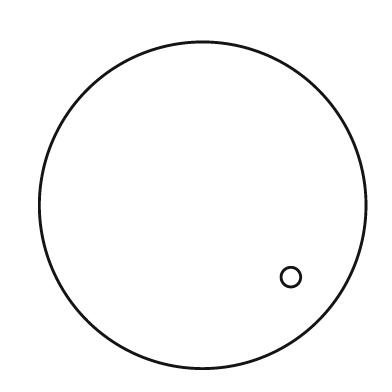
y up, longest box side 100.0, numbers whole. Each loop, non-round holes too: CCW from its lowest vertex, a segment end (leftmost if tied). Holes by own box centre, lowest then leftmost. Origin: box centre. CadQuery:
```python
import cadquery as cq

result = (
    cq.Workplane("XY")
    .moveTo(0.0, 0.0)
    .circle(50.0)
    .moveTo(27.0, -22.0)
    .circle(3.0)
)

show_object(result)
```